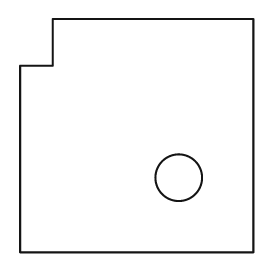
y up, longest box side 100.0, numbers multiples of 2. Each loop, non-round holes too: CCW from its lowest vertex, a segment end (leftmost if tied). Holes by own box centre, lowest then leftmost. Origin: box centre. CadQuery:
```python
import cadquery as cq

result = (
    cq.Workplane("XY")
    .moveTo(-50.0, -50.0)
    .lineTo(50.0, -50.0)
    .lineTo(50.0, 50.0)
    .lineTo(-36.0, 50.0)
    .lineTo(-36.0, 30.0)
    .lineTo(-50.0, 30.0)
    .close()
    .moveTo(18.0, -18.0)
    .circle(10.0)
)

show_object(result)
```